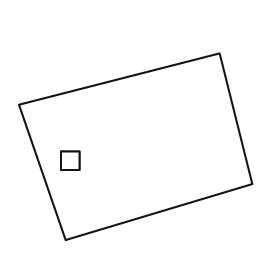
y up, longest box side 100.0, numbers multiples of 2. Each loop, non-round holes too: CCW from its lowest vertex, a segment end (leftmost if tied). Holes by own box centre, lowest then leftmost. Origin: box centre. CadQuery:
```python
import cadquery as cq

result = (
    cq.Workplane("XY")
    .moveTo(-30.0, -40.0)
    .lineTo(50.0, -16.0)
    .lineTo(36.0, 40.0)
    .lineTo(-50.0, 18.0)
    .close()
    .moveTo(-32.0, -10.0)
    .lineTo(-24.0, -10.0)
    .lineTo(-24.0, -2.0)
    .lineTo(-32.0, -2.0)
    .close()
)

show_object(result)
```